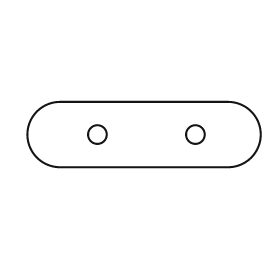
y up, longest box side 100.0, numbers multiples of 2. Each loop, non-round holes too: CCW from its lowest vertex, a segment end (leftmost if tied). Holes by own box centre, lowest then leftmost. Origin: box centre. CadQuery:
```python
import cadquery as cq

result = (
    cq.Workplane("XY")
    .moveTo(-36.0, -14.0)
    .lineTo(36.0, -14.0)
    .threePointArc((50.0, 0.0), (36.0, 14.0))
    .lineTo(-36.0, 14.0)
    .threePointArc((-50.0, 0.0), (-36.0, -14.0))
    .close()
    .moveTo(-20.0, 0.0)
    .circle(4.0)
    .moveTo(22.0, 0.0)
    .circle(4.0)
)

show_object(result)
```